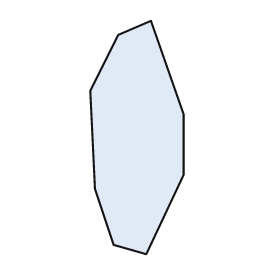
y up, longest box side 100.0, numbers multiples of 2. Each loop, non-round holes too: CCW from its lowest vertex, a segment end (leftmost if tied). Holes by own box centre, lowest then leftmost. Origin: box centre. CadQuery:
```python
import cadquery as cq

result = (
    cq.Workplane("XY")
    .moveTo(4.0, -50.0)
    .lineTo(20.0, -16.0)
    .lineTo(20.0, 10.0)
    .lineTo(6.0, 50.0)
    .lineTo(-8.0, 44.0)
    .lineTo(-20.0, 20.0)
    .lineTo(-18.0, -22.0)
    .lineTo(-10.0, -46.0)
    .close()
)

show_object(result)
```